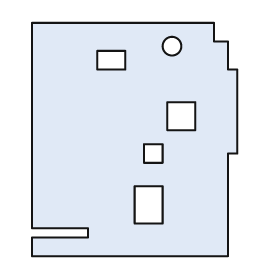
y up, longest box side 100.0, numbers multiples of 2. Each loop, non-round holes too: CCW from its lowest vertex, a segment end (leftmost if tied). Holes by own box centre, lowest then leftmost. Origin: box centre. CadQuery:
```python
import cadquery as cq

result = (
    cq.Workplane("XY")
    .moveTo(-44.0, -50.0)
    .lineTo(40.0, -50.0)
    .lineTo(40.0, -6.0)
    .lineTo(44.0, -6.0)
    .lineTo(44.0, 30.0)
    .lineTo(40.0, 30.0)
    .lineTo(40.0, 42.0)
    .lineTo(34.0, 42.0)
    .lineTo(34.0, 50.0)
    .lineTo(-44.0, 50.0)
    .lineTo(-44.0, -38.0)
    .lineTo(-20.0, -38.0)
    .lineTo(-20.0, -42.0)
    .lineTo(-44.0, -42.0)
    .close()
    .moveTo(0.0, -36.0)
    .lineTo(12.0, -36.0)
    .lineTo(12.0, -20.0)
    .lineTo(0.0, -20.0)
    .close()
    .moveTo(4.0, -10.0)
    .lineTo(12.0, -10.0)
    .lineTo(12.0, -2.0)
    .lineTo(4.0, -2.0)
    .close()
    .moveTo(14.0, 4.0)
    .lineTo(26.0, 4.0)
    .lineTo(26.0, 16.0)
    .lineTo(14.0, 16.0)
    .close()
    .moveTo(-16.0, 30.0)
    .lineTo(-4.0, 30.0)
    .lineTo(-4.0, 38.0)
    .lineTo(-16.0, 38.0)
    .close()
    .moveTo(16.0, 40.0)
    .circle(4.0)
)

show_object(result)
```